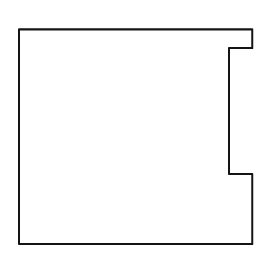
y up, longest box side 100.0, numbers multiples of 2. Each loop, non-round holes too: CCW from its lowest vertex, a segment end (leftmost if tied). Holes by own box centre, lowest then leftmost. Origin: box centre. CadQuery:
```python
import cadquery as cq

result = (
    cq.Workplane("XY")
    .moveTo(-50.0, -46.0)
    .lineTo(50.0, -46.0)
    .lineTo(50.0, -16.0)
    .lineTo(40.0, -16.0)
    .lineTo(40.0, 38.0)
    .lineTo(50.0, 38.0)
    .lineTo(50.0, 46.0)
    .lineTo(-50.0, 46.0)
    .close()
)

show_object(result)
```